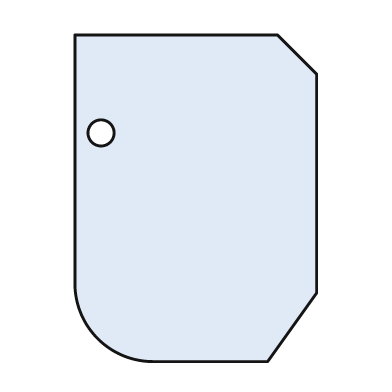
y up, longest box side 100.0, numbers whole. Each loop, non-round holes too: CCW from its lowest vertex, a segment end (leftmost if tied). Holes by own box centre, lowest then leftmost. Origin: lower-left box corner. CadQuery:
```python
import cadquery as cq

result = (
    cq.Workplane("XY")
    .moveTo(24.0, 0.0)
    .lineTo(59.0, 0.0)
    .lineTo(74.0, 21.0)
    .lineTo(74.0, 88.0)
    .lineTo(62.0, 100.0)
    .lineTo(0.0, 100.0)
    .lineTo(0.0, 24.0)
    .threePointArc((7.0, 7.0), (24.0, 0.0))
    .close()
    .moveTo(8.0, 70.0)
    .circle(4.0)
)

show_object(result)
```